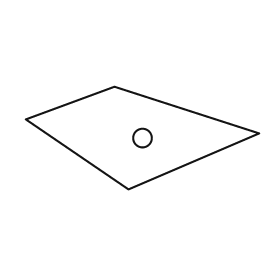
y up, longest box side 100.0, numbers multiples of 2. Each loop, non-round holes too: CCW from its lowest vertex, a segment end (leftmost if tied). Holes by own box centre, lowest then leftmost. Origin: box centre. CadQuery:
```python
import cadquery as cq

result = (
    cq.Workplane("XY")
    .moveTo(-6.0, -22.0)
    .lineTo(50.0, 2.0)
    .lineTo(-12.0, 22.0)
    .lineTo(-50.0, 8.0)
    .close()
    .moveTo(0.0, 0.0)
    .circle(4.0)
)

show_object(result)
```